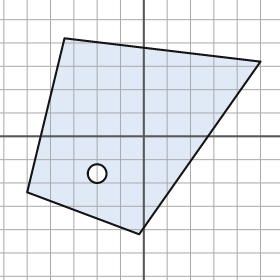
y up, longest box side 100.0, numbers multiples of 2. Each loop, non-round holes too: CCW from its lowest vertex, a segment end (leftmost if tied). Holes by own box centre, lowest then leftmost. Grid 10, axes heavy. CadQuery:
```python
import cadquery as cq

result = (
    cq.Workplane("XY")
    .moveTo(-2.0, -42.0)
    .lineTo(50.0, 32.0)
    .lineTo(-34.0, 42.0)
    .lineTo(-50.0, -24.0)
    .close()
    .moveTo(-20.0, -16.0)
    .circle(4.0)
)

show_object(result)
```